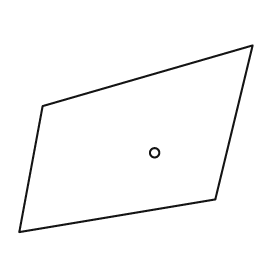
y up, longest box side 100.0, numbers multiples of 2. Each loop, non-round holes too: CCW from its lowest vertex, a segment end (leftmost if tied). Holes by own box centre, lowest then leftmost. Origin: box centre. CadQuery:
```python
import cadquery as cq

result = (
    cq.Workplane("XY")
    .moveTo(-50.0, -40.0)
    .lineTo(34.0, -26.0)
    .lineTo(50.0, 40.0)
    .lineTo(-40.0, 14.0)
    .close()
    .moveTo(8.0, -6.0)
    .circle(2.0)
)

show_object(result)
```